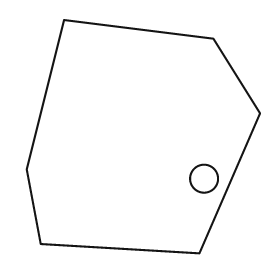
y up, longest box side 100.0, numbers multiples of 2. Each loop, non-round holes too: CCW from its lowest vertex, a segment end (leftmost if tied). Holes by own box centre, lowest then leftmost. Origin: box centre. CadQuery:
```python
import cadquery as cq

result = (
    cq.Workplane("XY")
    .moveTo(24.0, -50.0)
    .lineTo(50.0, 10.0)
    .lineTo(30.0, 42.0)
    .lineTo(-34.0, 50.0)
    .lineTo(-50.0, -14.0)
    .lineTo(-44.0, -46.0)
    .close()
    .moveTo(26.0, -18.0)
    .circle(6.0)
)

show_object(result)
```